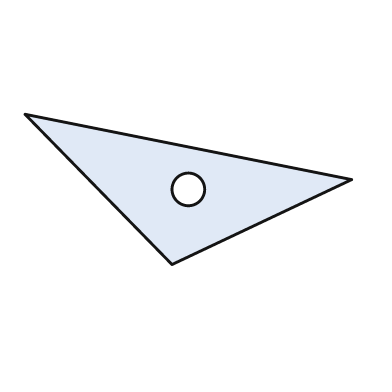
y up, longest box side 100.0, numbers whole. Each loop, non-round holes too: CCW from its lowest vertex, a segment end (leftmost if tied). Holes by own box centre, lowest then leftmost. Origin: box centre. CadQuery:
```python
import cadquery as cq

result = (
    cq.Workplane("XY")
    .moveTo(-5.0, -23.0)
    .lineTo(50.0, 3.0)
    .lineTo(-50.0, 23.0)
    .close()
    .moveTo(0.0, 0.0)
    .circle(5.0)
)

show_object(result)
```